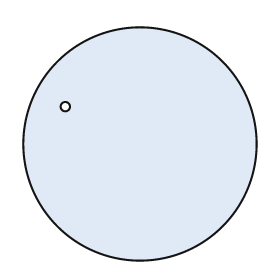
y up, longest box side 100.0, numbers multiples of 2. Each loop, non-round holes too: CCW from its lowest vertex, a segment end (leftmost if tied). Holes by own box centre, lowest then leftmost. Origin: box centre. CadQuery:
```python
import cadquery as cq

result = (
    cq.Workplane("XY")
    .moveTo(0.0, 0.0)
    .circle(50.0)
    .moveTo(-32.0, 16.0)
    .circle(2.0)
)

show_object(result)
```